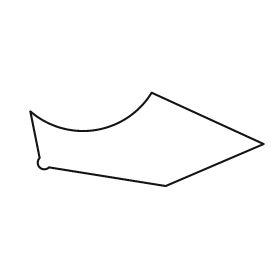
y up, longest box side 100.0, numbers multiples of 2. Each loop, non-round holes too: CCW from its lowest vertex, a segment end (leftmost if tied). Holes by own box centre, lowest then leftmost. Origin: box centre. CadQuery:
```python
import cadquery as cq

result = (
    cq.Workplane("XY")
    .moveTo(8.0, -20.0)
    .lineTo(50.0, -2.0)
    .lineTo(2.0, 20.0)
    .threePointArc((-22.0, 4.0), (-50.0, 12.0))
    .lineTo(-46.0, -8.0)
    .threePointArc((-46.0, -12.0), (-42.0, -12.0))
    .close()
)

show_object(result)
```